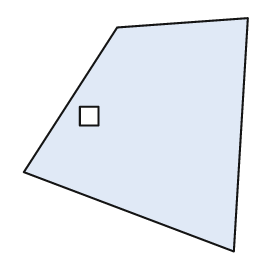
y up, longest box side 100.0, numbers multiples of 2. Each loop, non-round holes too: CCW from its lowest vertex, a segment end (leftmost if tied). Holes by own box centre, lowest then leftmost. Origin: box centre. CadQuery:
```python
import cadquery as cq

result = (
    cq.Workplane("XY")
    .moveTo(42.0, -50.0)
    .lineTo(48.0, 50.0)
    .lineTo(-8.0, 46.0)
    .lineTo(-48.0, -16.0)
    .close()
    .moveTo(-24.0, 4.0)
    .lineTo(-16.0, 4.0)
    .lineTo(-16.0, 12.0)
    .lineTo(-24.0, 12.0)
    .close()
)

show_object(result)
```